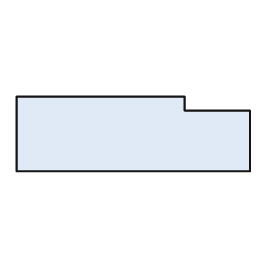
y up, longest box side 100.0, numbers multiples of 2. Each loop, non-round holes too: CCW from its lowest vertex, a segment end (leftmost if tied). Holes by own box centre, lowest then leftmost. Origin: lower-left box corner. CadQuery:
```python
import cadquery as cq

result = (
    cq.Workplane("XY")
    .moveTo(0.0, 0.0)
    .lineTo(100.0, 0.0)
    .lineTo(100.0, 26.0)
    .lineTo(72.0, 26.0)
    .lineTo(72.0, 32.0)
    .lineTo(0.0, 32.0)
    .close()
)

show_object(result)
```